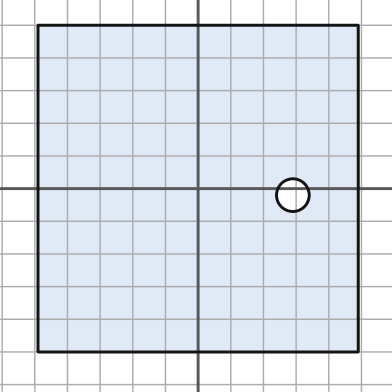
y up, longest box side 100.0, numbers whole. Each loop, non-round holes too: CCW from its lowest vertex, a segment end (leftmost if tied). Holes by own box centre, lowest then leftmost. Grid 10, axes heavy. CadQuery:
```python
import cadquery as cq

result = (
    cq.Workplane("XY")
    .moveTo(-49.0, -50.0)
    .lineTo(49.0, -50.0)
    .lineTo(49.0, 50.0)
    .lineTo(-49.0, 50.0)
    .close()
    .moveTo(29.0, -2.0)
    .circle(5.0)
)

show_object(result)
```